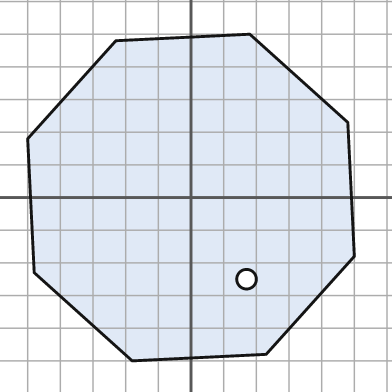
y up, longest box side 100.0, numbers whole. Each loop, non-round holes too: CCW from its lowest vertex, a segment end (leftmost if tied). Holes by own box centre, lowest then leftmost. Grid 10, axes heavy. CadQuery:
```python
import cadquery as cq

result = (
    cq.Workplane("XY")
    .moveTo(-18.0, -50.0)
    .lineTo(23.0, -48.0)
    .lineTo(50.0, -18.0)
    .lineTo(48.0, 23.0)
    .lineTo(18.0, 50.0)
    .lineTo(-23.0, 48.0)
    .lineTo(-50.0, 18.0)
    .lineTo(-48.0, -23.0)
    .close()
    .moveTo(17.0, -25.0)
    .circle(3.0)
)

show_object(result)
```